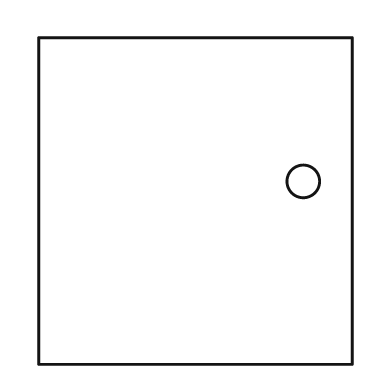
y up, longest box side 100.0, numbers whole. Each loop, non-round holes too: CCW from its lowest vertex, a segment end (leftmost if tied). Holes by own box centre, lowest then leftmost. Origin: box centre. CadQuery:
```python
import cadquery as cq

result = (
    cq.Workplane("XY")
    .moveTo(-48.0, -50.0)
    .lineTo(48.0, -50.0)
    .lineTo(48.0, 50.0)
    .lineTo(-48.0, 50.0)
    .close()
    .moveTo(33.0, 6.0)
    .circle(5.0)
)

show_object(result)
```